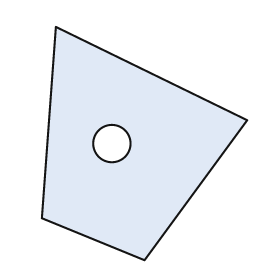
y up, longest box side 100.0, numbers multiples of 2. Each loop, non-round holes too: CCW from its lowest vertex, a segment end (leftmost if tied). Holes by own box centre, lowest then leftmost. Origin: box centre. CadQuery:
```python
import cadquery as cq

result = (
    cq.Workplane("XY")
    .moveTo(0.0, -50.0)
    .lineTo(44.0, 10.0)
    .lineTo(-38.0, 50.0)
    .lineTo(-44.0, -32.0)
    .close()
    .moveTo(-14.0, 0.0)
    .circle(8.0)
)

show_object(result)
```